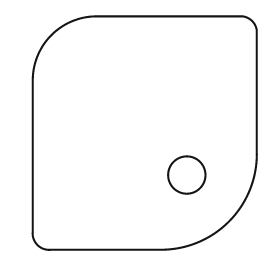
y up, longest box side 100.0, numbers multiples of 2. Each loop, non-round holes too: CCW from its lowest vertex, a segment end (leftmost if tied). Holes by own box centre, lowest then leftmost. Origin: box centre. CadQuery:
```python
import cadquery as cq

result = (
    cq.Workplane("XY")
    .moveTo(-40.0, -50.0)
    .lineTo(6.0, -50.0)
    .threePointArc((36.0, -38.0), (48.0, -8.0))
    .lineTo(48.0, 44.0)
    .threePointArc((46.0, 48.0), (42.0, 50.0))
    .lineTo(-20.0, 50.0)
    .threePointArc((-40.0, 42.0), (-48.0, 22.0))
    .lineTo(-48.0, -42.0)
    .threePointArc((-46.0, -48.0), (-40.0, -50.0))
    .close()
    .moveTo(18.0, -18.0)
    .circle(8.0)
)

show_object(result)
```